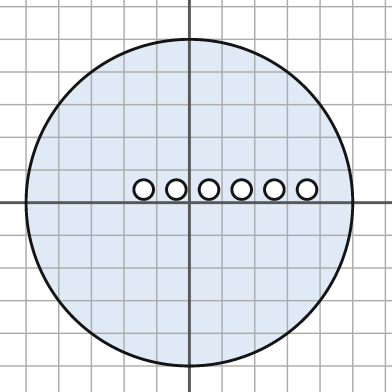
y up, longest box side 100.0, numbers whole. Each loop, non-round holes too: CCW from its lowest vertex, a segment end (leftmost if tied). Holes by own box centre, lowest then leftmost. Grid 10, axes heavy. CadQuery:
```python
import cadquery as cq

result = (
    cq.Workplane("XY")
    .moveTo(0.0, 0.0)
    .circle(50.0)
    .moveTo(-14.0, 4.0)
    .circle(3.0)
    .moveTo(-4.0, 4.0)
    .circle(3.0)
    .moveTo(6.0, 4.0)
    .circle(3.0)
    .moveTo(16.0, 4.0)
    .circle(3.0)
    .moveTo(26.0, 4.0)
    .circle(3.0)
    .moveTo(36.0, 4.0)
    .circle(3.0)
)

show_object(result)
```